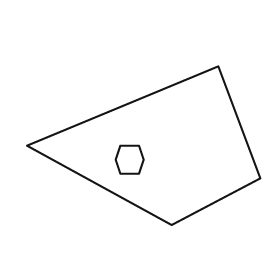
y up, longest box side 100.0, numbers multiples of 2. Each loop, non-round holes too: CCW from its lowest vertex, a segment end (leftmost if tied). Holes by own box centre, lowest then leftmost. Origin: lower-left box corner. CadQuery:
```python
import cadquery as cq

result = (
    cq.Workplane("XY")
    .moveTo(62.0, 0.0)
    .lineTo(100.0, 20.0)
    .lineTo(82.0, 68.0)
    .lineTo(0.0, 34.0)
    .close()
    .moveTo(40.0, 22.0)
    .lineTo(48.0, 22.0)
    .lineTo(50.0, 28.0)
    .lineTo(48.0, 34.0)
    .lineTo(40.0, 34.0)
    .lineTo(38.0, 28.0)
    .close()
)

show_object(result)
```